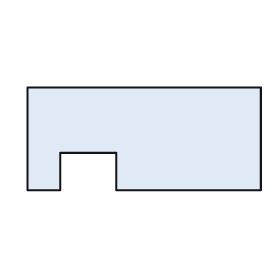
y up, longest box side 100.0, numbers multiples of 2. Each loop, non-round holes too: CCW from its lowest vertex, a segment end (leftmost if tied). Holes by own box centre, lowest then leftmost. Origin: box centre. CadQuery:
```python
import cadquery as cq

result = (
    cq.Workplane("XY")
    .moveTo(-50.0, -22.0)
    .lineTo(-36.0, -22.0)
    .lineTo(-36.0, -6.0)
    .lineTo(-12.0, -6.0)
    .lineTo(-12.0, -22.0)
    .lineTo(50.0, -22.0)
    .lineTo(50.0, 22.0)
    .lineTo(-50.0, 22.0)
    .close()
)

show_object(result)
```